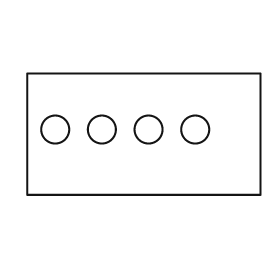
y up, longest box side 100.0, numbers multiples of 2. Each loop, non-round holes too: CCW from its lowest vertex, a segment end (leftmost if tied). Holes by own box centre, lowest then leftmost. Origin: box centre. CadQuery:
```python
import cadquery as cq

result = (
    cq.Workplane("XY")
    .moveTo(-50.0, -26.0)
    .lineTo(50.0, -26.0)
    .lineTo(50.0, 26.0)
    .lineTo(-50.0, 26.0)
    .close()
    .moveTo(-38.0, 2.0)
    .circle(6.0)
    .moveTo(-18.0, 2.0)
    .circle(6.0)
    .moveTo(2.0, 2.0)
    .circle(6.0)
    .moveTo(22.0, 2.0)
    .circle(6.0)
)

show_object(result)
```